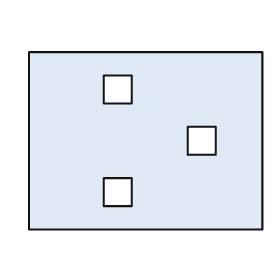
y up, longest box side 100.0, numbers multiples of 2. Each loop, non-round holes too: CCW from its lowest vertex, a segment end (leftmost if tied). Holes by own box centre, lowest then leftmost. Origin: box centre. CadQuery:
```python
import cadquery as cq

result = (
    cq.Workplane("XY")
    .moveTo(-50.0, -38.0)
    .lineTo(50.0, -38.0)
    .lineTo(50.0, 38.0)
    .lineTo(-50.0, 38.0)
    .close()
    .moveTo(-18.0, -28.0)
    .lineTo(-6.0, -28.0)
    .lineTo(-6.0, -16.0)
    .lineTo(-18.0, -16.0)
    .close()
    .moveTo(18.0, -6.0)
    .lineTo(30.0, -6.0)
    .lineTo(30.0, 6.0)
    .lineTo(18.0, 6.0)
    .close()
    .moveTo(-18.0, 16.0)
    .lineTo(-6.0, 16.0)
    .lineTo(-6.0, 28.0)
    .lineTo(-18.0, 28.0)
    .close()
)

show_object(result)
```